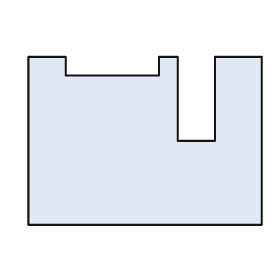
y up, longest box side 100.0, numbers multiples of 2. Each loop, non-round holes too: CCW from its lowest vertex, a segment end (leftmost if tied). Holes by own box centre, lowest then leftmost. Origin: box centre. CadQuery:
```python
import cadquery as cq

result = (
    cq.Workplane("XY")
    .moveTo(-50.0, -36.0)
    .lineTo(50.0, -36.0)
    .lineTo(50.0, 36.0)
    .lineTo(30.0, 36.0)
    .lineTo(30.0, 0.0)
    .lineTo(14.0, 0.0)
    .lineTo(14.0, 36.0)
    .lineTo(6.0, 36.0)
    .lineTo(6.0, 28.0)
    .lineTo(-34.0, 28.0)
    .lineTo(-34.0, 36.0)
    .lineTo(-50.0, 36.0)
    .close()
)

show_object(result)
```